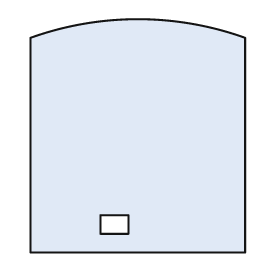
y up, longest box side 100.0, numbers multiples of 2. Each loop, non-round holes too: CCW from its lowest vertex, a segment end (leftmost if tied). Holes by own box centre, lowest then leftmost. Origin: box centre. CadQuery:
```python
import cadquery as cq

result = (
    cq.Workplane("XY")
    .moveTo(-46.0, -50.0)
    .lineTo(46.0, -50.0)
    .lineTo(46.0, 42.0)
    .threePointArc((0.0, 50.0), (-46.0, 42.0))
    .close()
    .moveTo(-16.0, -42.0)
    .lineTo(-4.0, -42.0)
    .lineTo(-4.0, -34.0)
    .lineTo(-16.0, -34.0)
    .close()
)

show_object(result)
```